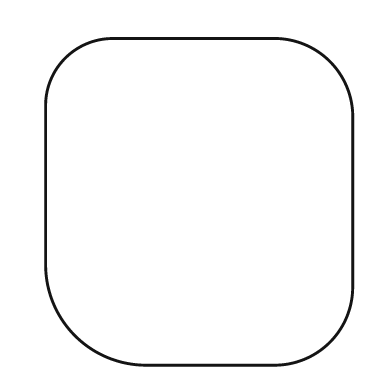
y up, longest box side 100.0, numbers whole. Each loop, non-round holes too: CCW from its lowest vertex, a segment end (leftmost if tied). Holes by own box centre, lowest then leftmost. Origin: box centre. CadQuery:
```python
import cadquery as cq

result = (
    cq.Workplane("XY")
    .moveTo(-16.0, -50.0)
    .lineTo(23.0, -50.0)
    .threePointArc((40.0, -43.0), (47.0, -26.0))
    .lineTo(47.0, 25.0)
    .threePointArc((40.0, 43.0), (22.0, 50.0))
    .lineTo(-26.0, 50.0)
    .threePointArc((-41.0, 44.0), (-47.0, 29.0))
    .lineTo(-47.0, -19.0)
    .threePointArc((-38.0, -41.0), (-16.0, -50.0))
    .close()
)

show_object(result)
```